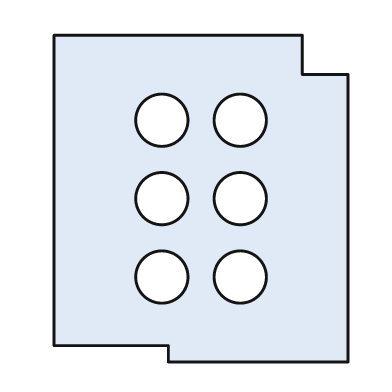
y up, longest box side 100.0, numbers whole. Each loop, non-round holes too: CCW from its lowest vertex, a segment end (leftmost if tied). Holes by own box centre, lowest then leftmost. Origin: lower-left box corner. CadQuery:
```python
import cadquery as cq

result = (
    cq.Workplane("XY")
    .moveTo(35.0, 0.0)
    .lineTo(90.0, 0.0)
    .lineTo(90.0, 88.0)
    .lineTo(76.0, 88.0)
    .lineTo(76.0, 100.0)
    .lineTo(0.0, 100.0)
    .lineTo(0.0, 5.0)
    .lineTo(35.0, 5.0)
    .close()
    .moveTo(33.0, 26.0)
    .circle(8.0)
    .moveTo(57.0, 26.0)
    .circle(8.0)
    .moveTo(33.0, 50.0)
    .circle(8.0)
    .moveTo(57.0, 50.0)
    .circle(8.0)
    .moveTo(33.0, 74.0)
    .circle(8.0)
    .moveTo(57.0, 74.0)
    .circle(8.0)
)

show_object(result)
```